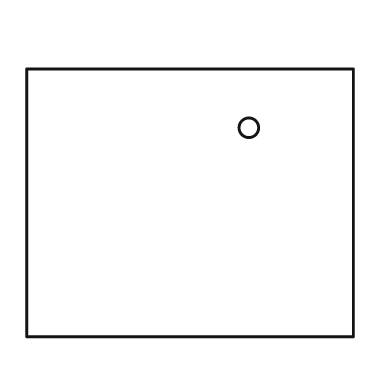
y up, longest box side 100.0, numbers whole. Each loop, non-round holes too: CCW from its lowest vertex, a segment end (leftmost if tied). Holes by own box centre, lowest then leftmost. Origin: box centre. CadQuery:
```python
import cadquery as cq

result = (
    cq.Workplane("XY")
    .moveTo(-50.0, -41.0)
    .lineTo(50.0, -41.0)
    .lineTo(50.0, 41.0)
    .lineTo(-50.0, 41.0)
    .close()
    .moveTo(18.0, 23.0)
    .circle(3.0)
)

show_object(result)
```